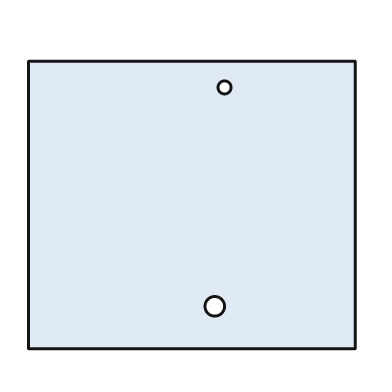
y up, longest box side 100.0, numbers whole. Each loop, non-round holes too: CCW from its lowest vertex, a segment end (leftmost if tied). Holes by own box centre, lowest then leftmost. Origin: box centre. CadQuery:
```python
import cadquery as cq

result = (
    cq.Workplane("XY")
    .moveTo(-50.0, -44.0)
    .lineTo(50.0, -44.0)
    .lineTo(50.0, 44.0)
    .lineTo(-50.0, 44.0)
    .close()
    .moveTo(7.0, -31.0)
    .circle(3.0)
    .moveTo(10.0, 36.0)
    .circle(2.0)
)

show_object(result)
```